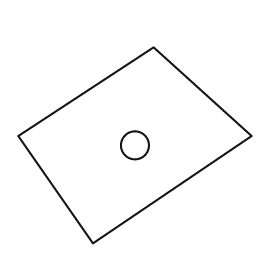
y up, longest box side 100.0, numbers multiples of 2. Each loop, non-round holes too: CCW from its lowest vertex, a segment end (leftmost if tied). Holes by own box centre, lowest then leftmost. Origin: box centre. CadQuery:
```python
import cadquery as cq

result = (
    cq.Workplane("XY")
    .moveTo(-18.0, -42.0)
    .lineTo(50.0, 4.0)
    .lineTo(8.0, 42.0)
    .lineTo(-50.0, 4.0)
    .close()
    .moveTo(0.0, 0.0)
    .circle(6.0)
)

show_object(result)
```